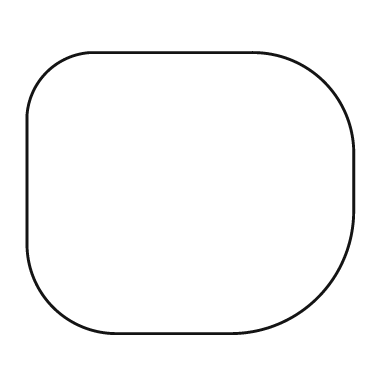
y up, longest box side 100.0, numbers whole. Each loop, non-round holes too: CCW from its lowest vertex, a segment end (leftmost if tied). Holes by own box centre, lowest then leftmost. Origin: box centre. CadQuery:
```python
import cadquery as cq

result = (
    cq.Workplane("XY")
    .moveTo(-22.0, -43.0)
    .lineTo(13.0, -43.0)
    .threePointArc((39.0, -32.0), (50.0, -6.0))
    .lineTo(50.0, 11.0)
    .threePointArc((41.0, 34.0), (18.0, 43.0))
    .lineTo(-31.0, 43.0)
    .threePointArc((-44.0, 37.0), (-50.0, 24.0))
    .lineTo(-50.0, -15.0)
    .threePointArc((-42.0, -35.0), (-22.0, -43.0))
    .close()
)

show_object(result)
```